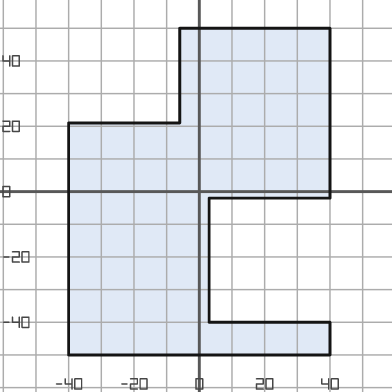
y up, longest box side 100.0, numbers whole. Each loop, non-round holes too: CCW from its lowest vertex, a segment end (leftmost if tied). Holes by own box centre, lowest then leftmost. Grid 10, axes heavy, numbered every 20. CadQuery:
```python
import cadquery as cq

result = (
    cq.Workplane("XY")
    .moveTo(-40.0, -50.0)
    .lineTo(40.0, -50.0)
    .lineTo(40.0, -40.0)
    .lineTo(3.0, -40.0)
    .lineTo(3.0, -2.0)
    .lineTo(40.0, -2.0)
    .lineTo(40.0, 50.0)
    .lineTo(-6.0, 50.0)
    .lineTo(-6.0, 21.0)
    .lineTo(-40.0, 21.0)
    .close()
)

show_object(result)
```